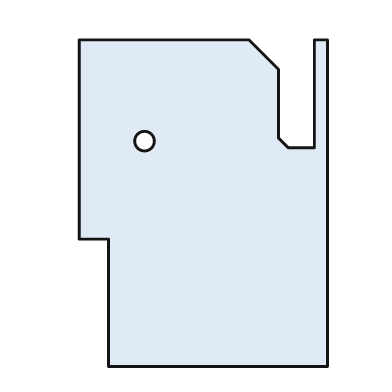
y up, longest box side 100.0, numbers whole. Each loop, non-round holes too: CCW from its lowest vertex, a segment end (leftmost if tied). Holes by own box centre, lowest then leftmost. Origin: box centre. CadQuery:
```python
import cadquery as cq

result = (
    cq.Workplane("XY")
    .moveTo(-29.0, -50.0)
    .lineTo(38.0, -50.0)
    .lineTo(38.0, 50.0)
    .lineTo(34.0, 50.0)
    .lineTo(34.0, 17.0)
    .lineTo(26.0, 17.0)
    .lineTo(23.0, 20.0)
    .lineTo(23.0, 41.0)
    .lineTo(14.0, 50.0)
    .lineTo(-38.0, 50.0)
    .lineTo(-38.0, -11.0)
    .lineTo(-29.0, -11.0)
    .close()
    .moveTo(-18.0, 19.0)
    .circle(3.0)
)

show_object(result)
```